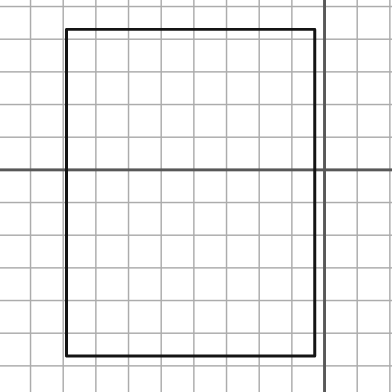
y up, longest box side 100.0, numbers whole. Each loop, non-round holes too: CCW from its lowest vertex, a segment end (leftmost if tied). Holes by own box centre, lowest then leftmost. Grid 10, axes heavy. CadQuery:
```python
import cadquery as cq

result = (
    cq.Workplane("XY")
    .moveTo(-79.0, -57.0)
    .lineTo(-3.0, -57.0)
    .lineTo(-3.0, 43.0)
    .lineTo(-79.0, 43.0)
    .close()
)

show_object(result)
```